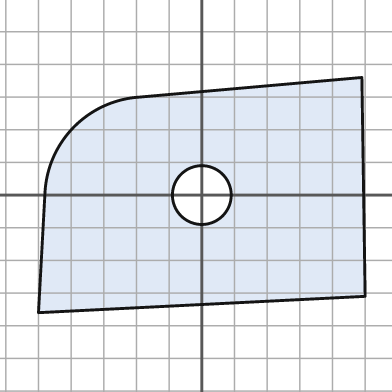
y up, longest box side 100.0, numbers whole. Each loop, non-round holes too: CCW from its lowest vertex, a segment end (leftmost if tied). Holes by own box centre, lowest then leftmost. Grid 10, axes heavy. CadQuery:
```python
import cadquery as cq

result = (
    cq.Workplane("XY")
    .moveTo(-50.0, -36.0)
    .lineTo(50.0, -31.0)
    .lineTo(49.0, 36.0)
    .lineTo(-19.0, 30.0)
    .threePointArc((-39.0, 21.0), (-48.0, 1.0))
    .close()
    .moveTo(0.0, 0.0)
    .circle(9.0)
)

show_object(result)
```